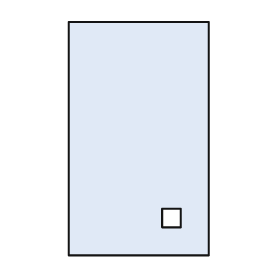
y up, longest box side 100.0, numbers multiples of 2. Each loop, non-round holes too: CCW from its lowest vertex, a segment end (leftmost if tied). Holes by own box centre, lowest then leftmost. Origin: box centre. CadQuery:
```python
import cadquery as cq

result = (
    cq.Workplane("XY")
    .moveTo(-30.0, -50.0)
    .lineTo(30.0, -50.0)
    .lineTo(30.0, 50.0)
    .lineTo(-30.0, 50.0)
    .close()
    .moveTo(10.0, -38.0)
    .lineTo(18.0, -38.0)
    .lineTo(18.0, -30.0)
    .lineTo(10.0, -30.0)
    .close()
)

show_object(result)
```